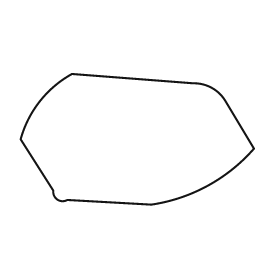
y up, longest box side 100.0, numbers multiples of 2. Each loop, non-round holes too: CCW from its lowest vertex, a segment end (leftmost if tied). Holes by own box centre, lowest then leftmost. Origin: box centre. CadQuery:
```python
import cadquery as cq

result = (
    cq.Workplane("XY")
    .moveTo(6.0, -28.0)
    .threePointArc((30.0, -20.0), (50.0, -4.0))
    .lineTo(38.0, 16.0)
    .threePointArc((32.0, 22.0), (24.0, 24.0))
    .lineTo(-28.0, 28.0)
    .threePointArc((-42.0, 16.0), (-50.0, 0.0))
    .lineTo(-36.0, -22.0)
    .threePointArc((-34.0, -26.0), (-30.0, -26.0))
    .close()
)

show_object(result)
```